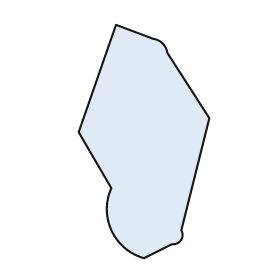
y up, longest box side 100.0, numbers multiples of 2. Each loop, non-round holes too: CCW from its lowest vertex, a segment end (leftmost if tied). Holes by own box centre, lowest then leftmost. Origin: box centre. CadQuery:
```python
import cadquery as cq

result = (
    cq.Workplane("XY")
    .moveTo(0.0, -50.0)
    .lineTo(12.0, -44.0)
    .threePointArc((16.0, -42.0), (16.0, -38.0))
    .lineTo(28.0, 10.0)
    .lineTo(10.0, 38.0)
    .threePointArc((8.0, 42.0), (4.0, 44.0))
    .lineTo(-12.0, 50.0)
    .lineTo(-28.0, 4.0)
    .lineTo(-14.0, -20.0)
    .threePointArc((-14.0, -38.0), (0.0, -50.0))
    .close()
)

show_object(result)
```